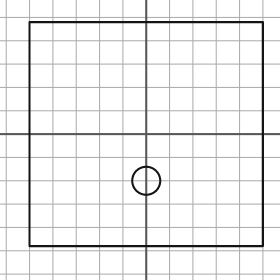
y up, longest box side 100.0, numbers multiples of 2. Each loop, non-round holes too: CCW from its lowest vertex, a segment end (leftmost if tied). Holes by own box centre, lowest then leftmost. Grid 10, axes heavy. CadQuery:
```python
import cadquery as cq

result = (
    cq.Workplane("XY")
    .moveTo(-50.0, -48.0)
    .lineTo(50.0, -48.0)
    .lineTo(50.0, 48.0)
    .lineTo(-50.0, 48.0)
    .close()
    .moveTo(0.0, -20.0)
    .circle(6.0)
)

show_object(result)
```